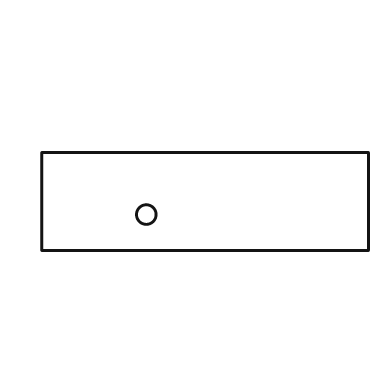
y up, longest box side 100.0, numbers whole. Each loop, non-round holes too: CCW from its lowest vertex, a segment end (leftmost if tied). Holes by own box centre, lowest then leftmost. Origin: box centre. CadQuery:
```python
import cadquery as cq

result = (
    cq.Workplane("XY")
    .moveTo(-50.0, -15.0)
    .lineTo(50.0, -15.0)
    .lineTo(50.0, 15.0)
    .lineTo(-50.0, 15.0)
    .close()
    .moveTo(-18.0, -4.0)
    .circle(3.0)
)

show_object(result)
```